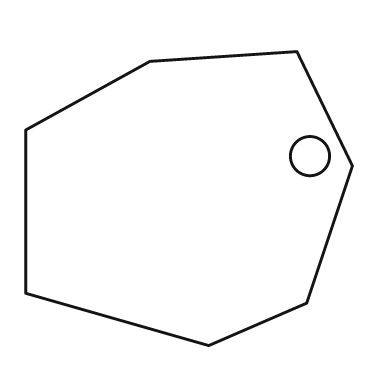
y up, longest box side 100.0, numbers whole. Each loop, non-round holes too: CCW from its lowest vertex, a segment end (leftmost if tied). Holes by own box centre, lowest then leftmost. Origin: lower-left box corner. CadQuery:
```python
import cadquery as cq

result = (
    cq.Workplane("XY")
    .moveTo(56.0, 0.0)
    .lineTo(86.0, 13.0)
    .lineTo(100.0, 55.0)
    .lineTo(83.0, 90.0)
    .lineTo(38.0, 87.0)
    .lineTo(0.0, 66.0)
    .lineTo(0.0, 16.0)
    .close()
    .moveTo(87.0, 58.0)
    .circle(6.0)
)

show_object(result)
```